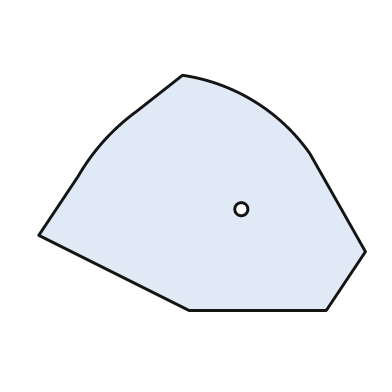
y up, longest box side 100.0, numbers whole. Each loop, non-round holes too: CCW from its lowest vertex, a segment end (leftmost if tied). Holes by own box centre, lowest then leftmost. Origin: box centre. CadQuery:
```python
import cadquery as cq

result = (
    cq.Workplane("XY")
    .moveTo(-4.0, -36.0)
    .lineTo(38.0, -36.0)
    .lineTo(50.0, -18.0)
    .lineTo(33.0, 12.0)
    .threePointArc((16.0, 28.0), (-6.0, 36.0))
    .lineTo(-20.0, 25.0)
    .threePointArc((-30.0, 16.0), (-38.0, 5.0))
    .lineTo(-50.0, -13.0)
    .close()
    .moveTo(12.0, -5.0)
    .circle(2.0)
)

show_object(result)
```